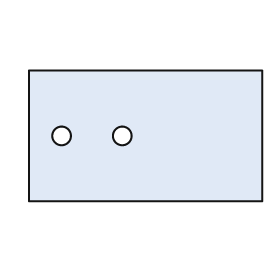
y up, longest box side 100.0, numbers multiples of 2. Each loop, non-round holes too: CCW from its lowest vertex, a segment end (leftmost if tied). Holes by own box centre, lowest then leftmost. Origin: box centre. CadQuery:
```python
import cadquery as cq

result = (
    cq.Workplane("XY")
    .moveTo(-50.0, -28.0)
    .lineTo(50.0, -28.0)
    .lineTo(50.0, 28.0)
    .lineTo(-50.0, 28.0)
    .close()
    .moveTo(-36.0, 0.0)
    .circle(4.0)
    .moveTo(-10.0, 0.0)
    .circle(4.0)
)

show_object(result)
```